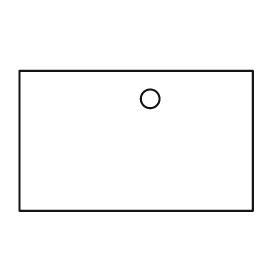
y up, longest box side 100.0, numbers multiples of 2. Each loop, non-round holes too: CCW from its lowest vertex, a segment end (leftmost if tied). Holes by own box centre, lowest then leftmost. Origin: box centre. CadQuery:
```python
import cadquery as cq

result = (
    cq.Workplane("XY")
    .moveTo(-50.0, -30.0)
    .lineTo(50.0, -30.0)
    .lineTo(50.0, 30.0)
    .lineTo(-50.0, 30.0)
    .close()
    .moveTo(6.0, 18.0)
    .circle(4.0)
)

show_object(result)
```